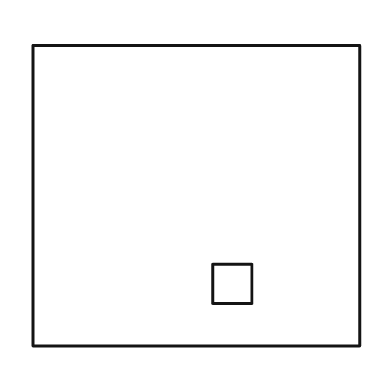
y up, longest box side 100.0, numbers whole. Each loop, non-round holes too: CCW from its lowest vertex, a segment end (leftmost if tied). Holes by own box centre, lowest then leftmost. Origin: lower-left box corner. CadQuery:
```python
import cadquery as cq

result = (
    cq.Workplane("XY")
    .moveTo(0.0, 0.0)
    .lineTo(100.0, 0.0)
    .lineTo(100.0, 92.0)
    .lineTo(0.0, 92.0)
    .close()
    .moveTo(55.0, 13.0)
    .lineTo(67.0, 13.0)
    .lineTo(67.0, 25.0)
    .lineTo(55.0, 25.0)
    .close()
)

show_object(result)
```